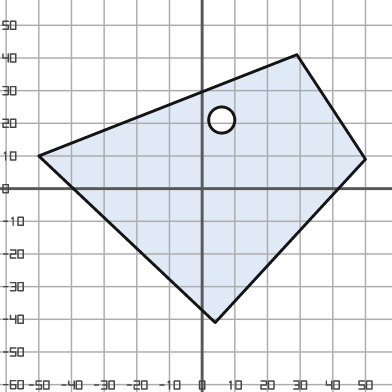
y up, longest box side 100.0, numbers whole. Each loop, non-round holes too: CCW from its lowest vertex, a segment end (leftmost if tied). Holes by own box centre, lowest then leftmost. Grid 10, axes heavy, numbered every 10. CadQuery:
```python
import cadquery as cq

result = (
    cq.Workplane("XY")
    .moveTo(4.0, -41.0)
    .lineTo(50.0, 9.0)
    .lineTo(29.0, 41.0)
    .lineTo(-50.0, 10.0)
    .close()
    .moveTo(6.0, 21.0)
    .circle(4.0)
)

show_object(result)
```